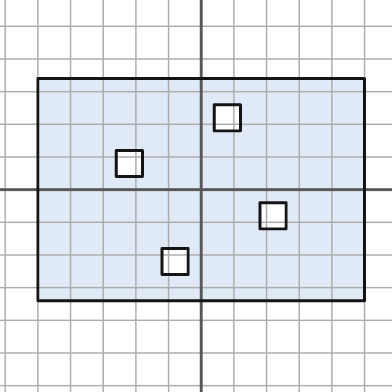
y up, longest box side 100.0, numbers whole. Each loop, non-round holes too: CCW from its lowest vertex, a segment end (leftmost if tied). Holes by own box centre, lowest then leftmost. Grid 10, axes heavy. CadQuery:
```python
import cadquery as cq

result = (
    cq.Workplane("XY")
    .moveTo(-50.0, -34.0)
    .lineTo(50.0, -34.0)
    .lineTo(50.0, 34.0)
    .lineTo(-50.0, 34.0)
    .close()
    .moveTo(-12.0, -26.0)
    .lineTo(-4.0, -26.0)
    .lineTo(-4.0, -18.0)
    .lineTo(-12.0, -18.0)
    .close()
    .moveTo(18.0, -12.0)
    .lineTo(26.0, -12.0)
    .lineTo(26.0, -4.0)
    .lineTo(18.0, -4.0)
    .close()
    .moveTo(-26.0, 4.0)
    .lineTo(-18.0, 4.0)
    .lineTo(-18.0, 12.0)
    .lineTo(-26.0, 12.0)
    .close()
    .moveTo(4.0, 18.0)
    .lineTo(12.0, 18.0)
    .lineTo(12.0, 26.0)
    .lineTo(4.0, 26.0)
    .close()
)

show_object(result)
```